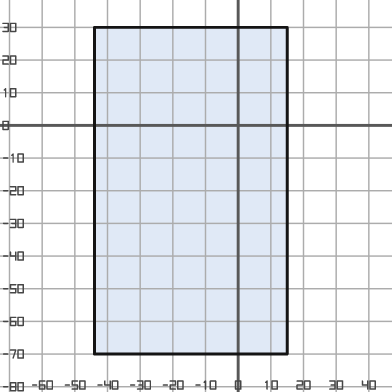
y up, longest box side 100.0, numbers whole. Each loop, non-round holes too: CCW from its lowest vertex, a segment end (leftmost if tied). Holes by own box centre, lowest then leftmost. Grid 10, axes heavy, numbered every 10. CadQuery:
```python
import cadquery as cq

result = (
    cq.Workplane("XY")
    .moveTo(-44.0, -70.0)
    .lineTo(15.0, -70.0)
    .lineTo(15.0, 30.0)
    .lineTo(-44.0, 30.0)
    .close()
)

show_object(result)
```